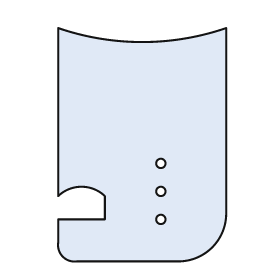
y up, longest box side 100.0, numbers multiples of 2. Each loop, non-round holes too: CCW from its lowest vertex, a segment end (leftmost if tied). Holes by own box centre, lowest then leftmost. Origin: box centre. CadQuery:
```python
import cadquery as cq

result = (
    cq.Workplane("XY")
    .moveTo(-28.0, -50.0)
    .lineTo(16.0, -50.0)
    .threePointArc((30.0, -44.0), (36.0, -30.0))
    .lineTo(36.0, 50.0)
    .threePointArc((0.0, 44.0), (-36.0, 50.0))
    .lineTo(-36.0, -22.0)
    .threePointArc((-26.0, -18.0), (-16.0, -22.0))
    .lineTo(-16.0, -32.0)
    .lineTo(-36.0, -32.0)
    .lineTo(-36.0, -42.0)
    .threePointArc((-34.0, -48.0), (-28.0, -50.0))
    .close()
    .moveTo(8.0, -32.0)
    .circle(2.0)
    .moveTo(8.0, -20.0)
    .circle(2.0)
    .moveTo(8.0, -8.0)
    .circle(2.0)
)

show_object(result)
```